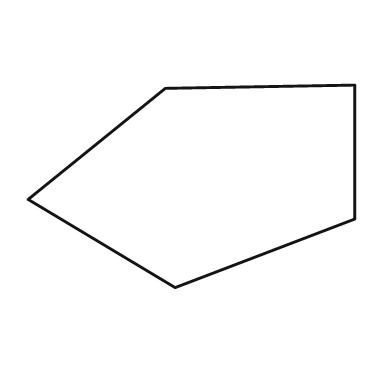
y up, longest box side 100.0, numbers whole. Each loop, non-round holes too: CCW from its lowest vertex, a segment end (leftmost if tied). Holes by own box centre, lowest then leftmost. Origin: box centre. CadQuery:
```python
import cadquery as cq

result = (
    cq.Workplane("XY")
    .moveTo(-5.0, -31.0)
    .lineTo(50.0, -10.0)
    .lineTo(50.0, 31.0)
    .lineTo(-8.0, 30.0)
    .lineTo(-50.0, -4.0)
    .close()
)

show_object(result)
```